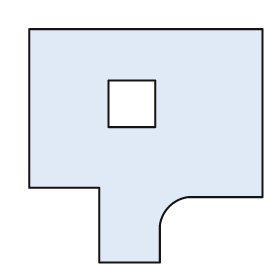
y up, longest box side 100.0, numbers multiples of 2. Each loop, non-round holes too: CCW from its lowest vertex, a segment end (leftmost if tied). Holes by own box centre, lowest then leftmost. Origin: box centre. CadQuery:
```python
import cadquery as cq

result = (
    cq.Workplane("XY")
    .moveTo(-20.0, -50.0)
    .lineTo(6.0, -50.0)
    .lineTo(6.0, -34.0)
    .threePointArc((10.0, -26.0), (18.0, -22.0))
    .lineTo(50.0, -22.0)
    .lineTo(50.0, 50.0)
    .lineTo(-50.0, 50.0)
    .lineTo(-50.0, -18.0)
    .lineTo(-20.0, -18.0)
    .close()
    .moveTo(-16.0, 8.0)
    .lineTo(4.0, 8.0)
    .lineTo(4.0, 28.0)
    .lineTo(-16.0, 28.0)
    .close()
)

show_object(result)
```